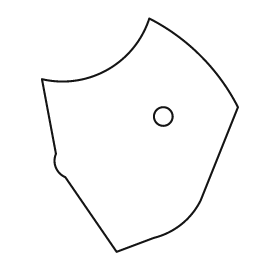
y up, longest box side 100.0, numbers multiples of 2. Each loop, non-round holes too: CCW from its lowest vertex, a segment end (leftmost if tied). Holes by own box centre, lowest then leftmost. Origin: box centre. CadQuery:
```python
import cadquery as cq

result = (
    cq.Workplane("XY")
    .moveTo(-10.0, -50.0)
    .lineTo(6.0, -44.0)
    .threePointArc((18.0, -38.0), (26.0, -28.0))
    .lineTo(42.0, 12.0)
    .threePointArc((26.0, 34.0), (4.0, 50.0))
    .threePointArc((-14.0, 28.0), (-42.0, 24.0))
    .lineTo(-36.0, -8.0)
    .threePointArc((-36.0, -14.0), (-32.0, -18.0))
    .close()
    .moveTo(10.0, 8.0)
    .circle(4.0)
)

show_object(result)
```